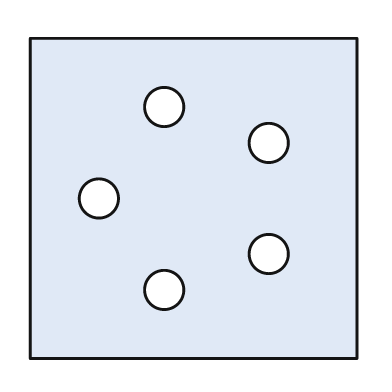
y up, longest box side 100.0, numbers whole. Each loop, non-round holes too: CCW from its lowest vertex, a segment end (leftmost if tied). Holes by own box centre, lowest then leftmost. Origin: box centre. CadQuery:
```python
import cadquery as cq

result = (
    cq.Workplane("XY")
    .moveTo(-50.0, -49.0)
    .lineTo(50.0, -49.0)
    .lineTo(50.0, 49.0)
    .lineTo(-50.0, 49.0)
    .close()
    .moveTo(-9.0, -28.0)
    .circle(6.0)
    .moveTo(23.0, -17.0)
    .circle(6.0)
    .moveTo(-29.0, 0.0)
    .circle(6.0)
    .moveTo(23.0, 17.0)
    .circle(6.0)
    .moveTo(-9.0, 28.0)
    .circle(6.0)
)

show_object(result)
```